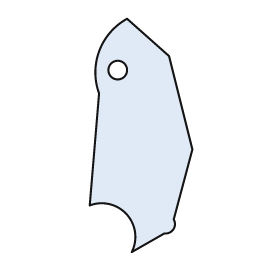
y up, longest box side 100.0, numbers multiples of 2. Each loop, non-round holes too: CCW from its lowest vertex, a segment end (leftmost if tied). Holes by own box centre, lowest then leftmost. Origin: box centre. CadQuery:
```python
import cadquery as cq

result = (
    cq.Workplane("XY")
    .moveTo(-4.0, -50.0)
    .lineTo(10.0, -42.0)
    .threePointArc((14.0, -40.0), (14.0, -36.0))
    .lineTo(22.0, -6.0)
    .lineTo(12.0, 34.0)
    .lineTo(-6.0, 50.0)
    .threePointArc((-18.0, 36.0), (-18.0, 18.0))
    .lineTo(-22.0, -30.0)
    .threePointArc((-6.0, -34.0), (-4.0, -50.0))
    .close()
    .moveTo(-10.0, 28.0)
    .circle(4.0)
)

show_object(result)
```